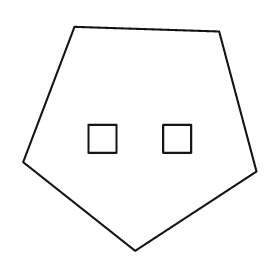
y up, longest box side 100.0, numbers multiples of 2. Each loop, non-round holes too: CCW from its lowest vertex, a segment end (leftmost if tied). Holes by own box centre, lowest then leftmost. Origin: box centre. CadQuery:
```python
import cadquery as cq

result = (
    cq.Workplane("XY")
    .moveTo(-2.0, -48.0)
    .lineTo(50.0, -14.0)
    .lineTo(34.0, 46.0)
    .lineTo(-28.0, 48.0)
    .lineTo(-50.0, -10.0)
    .close()
    .moveTo(-22.0, -6.0)
    .lineTo(-10.0, -6.0)
    .lineTo(-10.0, 6.0)
    .lineTo(-22.0, 6.0)
    .close()
    .moveTo(10.0, -6.0)
    .lineTo(22.0, -6.0)
    .lineTo(22.0, 6.0)
    .lineTo(10.0, 6.0)
    .close()
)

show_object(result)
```